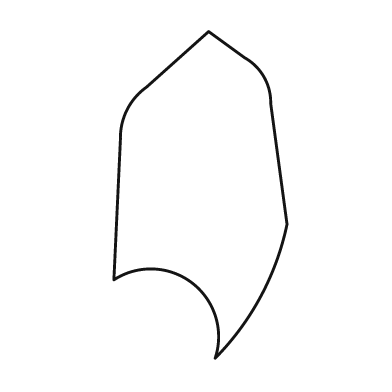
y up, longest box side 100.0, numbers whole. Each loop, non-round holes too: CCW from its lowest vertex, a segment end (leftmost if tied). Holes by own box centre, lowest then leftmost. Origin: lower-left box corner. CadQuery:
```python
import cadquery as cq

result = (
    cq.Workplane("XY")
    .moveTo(31.0, 0.0)
    .threePointArc((45.0, 19.0), (53.0, 41.0))
    .lineTo(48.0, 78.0)
    .threePointArc((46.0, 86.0), (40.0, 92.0))
    .lineTo(29.0, 100.0)
    .lineTo(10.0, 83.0)
    .threePointArc((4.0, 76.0), (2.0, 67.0))
    .lineTo(0.0, 24.0)
    .threePointArc((24.0, 23.0), (31.0, 0.0))
    .close()
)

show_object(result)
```